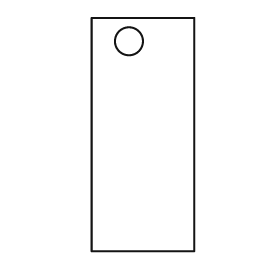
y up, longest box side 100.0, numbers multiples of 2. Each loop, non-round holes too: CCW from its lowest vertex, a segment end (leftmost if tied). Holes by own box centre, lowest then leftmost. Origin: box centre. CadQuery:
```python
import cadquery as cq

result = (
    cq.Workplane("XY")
    .moveTo(-22.0, -50.0)
    .lineTo(22.0, -50.0)
    .lineTo(22.0, 50.0)
    .lineTo(-22.0, 50.0)
    .close()
    .moveTo(-6.0, 40.0)
    .circle(6.0)
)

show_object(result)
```